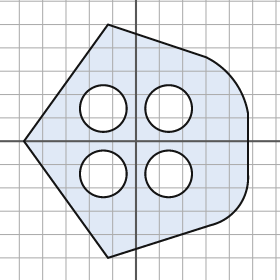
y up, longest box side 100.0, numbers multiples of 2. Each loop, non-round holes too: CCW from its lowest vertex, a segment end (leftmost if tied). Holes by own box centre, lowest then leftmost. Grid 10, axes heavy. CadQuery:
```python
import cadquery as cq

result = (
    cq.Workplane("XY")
    .moveTo(-12.0, -50.0)
    .lineTo(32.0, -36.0)
    .threePointArc((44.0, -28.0), (48.0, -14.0))
    .lineTo(48.0, 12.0)
    .threePointArc((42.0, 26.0), (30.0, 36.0))
    .lineTo(-12.0, 50.0)
    .lineTo(-48.0, 0.0)
    .close()
    .moveTo(-14.0, -14.0)
    .circle(10.0)
    .moveTo(14.0, -14.0)
    .circle(10.0)
    .moveTo(-14.0, 14.0)
    .circle(10.0)
    .moveTo(14.0, 14.0)
    .circle(10.0)
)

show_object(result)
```